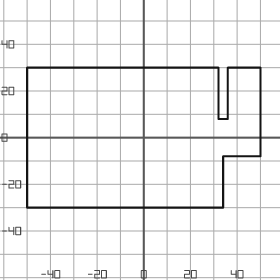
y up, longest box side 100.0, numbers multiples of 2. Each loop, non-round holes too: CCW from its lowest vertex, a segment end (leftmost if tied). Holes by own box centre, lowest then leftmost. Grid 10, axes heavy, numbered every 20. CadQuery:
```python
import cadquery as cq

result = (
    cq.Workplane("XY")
    .moveTo(-50.0, -30.0)
    .lineTo(34.0, -30.0)
    .lineTo(34.0, -8.0)
    .lineTo(50.0, -8.0)
    .lineTo(50.0, 30.0)
    .lineTo(36.0, 30.0)
    .lineTo(36.0, 8.0)
    .lineTo(32.0, 8.0)
    .lineTo(32.0, 30.0)
    .lineTo(-50.0, 30.0)
    .close()
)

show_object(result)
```